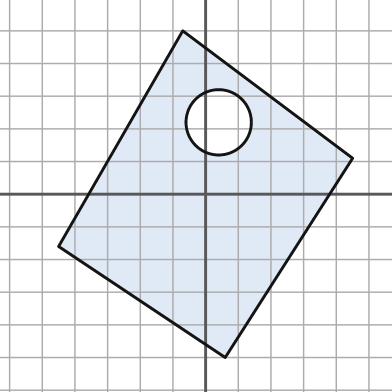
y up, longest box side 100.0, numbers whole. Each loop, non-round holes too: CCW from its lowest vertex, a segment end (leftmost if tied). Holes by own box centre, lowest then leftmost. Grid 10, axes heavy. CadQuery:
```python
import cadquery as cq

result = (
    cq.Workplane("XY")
    .moveTo(6.0, -50.0)
    .lineTo(45.0, 11.0)
    .lineTo(-7.0, 50.0)
    .lineTo(-45.0, -16.0)
    .close()
    .moveTo(4.0, 22.0)
    .circle(10.0)
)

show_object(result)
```